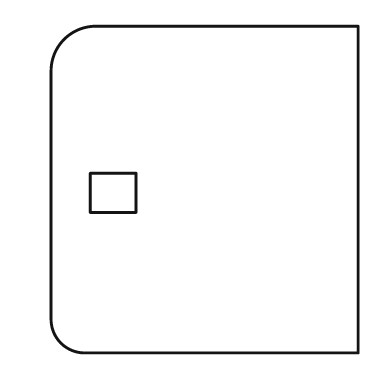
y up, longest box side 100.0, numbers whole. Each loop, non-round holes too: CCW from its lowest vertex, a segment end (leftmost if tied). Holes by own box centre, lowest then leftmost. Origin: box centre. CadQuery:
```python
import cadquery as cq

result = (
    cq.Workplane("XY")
    .moveTo(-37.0, -50.0)
    .lineTo(47.0, -50.0)
    .lineTo(47.0, 50.0)
    .lineTo(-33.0, 50.0)
    .threePointArc((-43.0, 46.0), (-47.0, 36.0))
    .lineTo(-47.0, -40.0)
    .threePointArc((-44.0, -47.0), (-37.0, -50.0))
    .close()
    .moveTo(-35.0, -7.0)
    .lineTo(-21.0, -7.0)
    .lineTo(-21.0, 5.0)
    .lineTo(-35.0, 5.0)
    .close()
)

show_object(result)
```